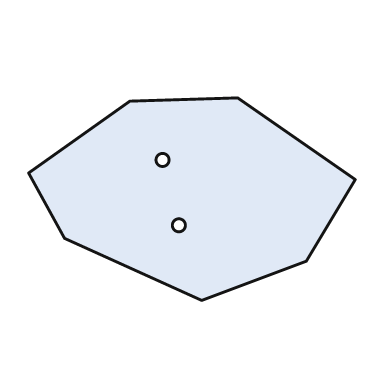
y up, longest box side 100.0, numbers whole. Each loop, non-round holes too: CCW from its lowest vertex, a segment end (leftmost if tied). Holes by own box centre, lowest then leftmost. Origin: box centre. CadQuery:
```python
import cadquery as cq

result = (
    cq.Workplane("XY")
    .moveTo(3.0, -31.0)
    .lineTo(35.0, -19.0)
    .lineTo(50.0, 6.0)
    .lineTo(14.0, 31.0)
    .lineTo(-19.0, 30.0)
    .lineTo(-50.0, 8.0)
    .lineTo(-39.0, -12.0)
    .close()
    .moveTo(-4.0, -8.0)
    .circle(2.0)
    .moveTo(-9.0, 12.0)
    .circle(2.0)
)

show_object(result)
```